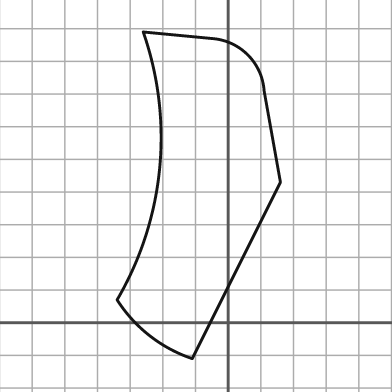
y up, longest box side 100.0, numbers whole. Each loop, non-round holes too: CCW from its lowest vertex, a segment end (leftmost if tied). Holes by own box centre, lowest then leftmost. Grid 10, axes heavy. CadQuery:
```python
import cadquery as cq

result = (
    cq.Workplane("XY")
    .moveTo(-11.0, -11.0)
    .lineTo(16.0, 43.0)
    .lineTo(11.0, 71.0)
    .threePointArc((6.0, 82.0), (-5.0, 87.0))
    .lineTo(-26.0, 89.0)
    .threePointArc((-21.0, 47.0), (-34.0, 7.0))
    .threePointArc((-24.0, -4.0), (-11.0, -11.0))
    .close()
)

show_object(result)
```